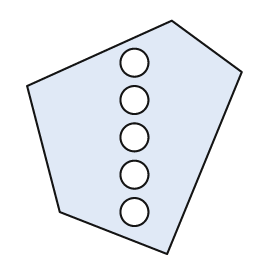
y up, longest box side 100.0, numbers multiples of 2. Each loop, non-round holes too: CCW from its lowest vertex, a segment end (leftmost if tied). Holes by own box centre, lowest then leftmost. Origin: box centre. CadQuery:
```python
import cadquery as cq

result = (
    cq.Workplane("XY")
    .moveTo(14.0, -50.0)
    .lineTo(46.0, 28.0)
    .lineTo(16.0, 50.0)
    .lineTo(-46.0, 22.0)
    .lineTo(-32.0, -32.0)
    .close()
    .moveTo(0.0, -32.0)
    .circle(6.0)
    .moveTo(0.0, -16.0)
    .circle(6.0)
    .moveTo(0.0, 0.0)
    .circle(6.0)
    .moveTo(0.0, 16.0)
    .circle(6.0)
    .moveTo(0.0, 32.0)
    .circle(6.0)
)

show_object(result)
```